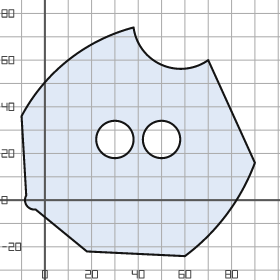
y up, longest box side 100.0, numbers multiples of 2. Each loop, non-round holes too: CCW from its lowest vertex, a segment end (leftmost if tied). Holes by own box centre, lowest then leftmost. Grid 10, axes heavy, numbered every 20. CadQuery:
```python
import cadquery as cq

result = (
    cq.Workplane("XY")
    .moveTo(60.0, -24.0)
    .threePointArc((78.0, -6.0), (90.0, 16.0))
    .lineTo(70.0, 60.0)
    .threePointArc((50.0, 58.0), (38.0, 74.0))
    .threePointArc((10.0, 60.0), (-10.0, 36.0))
    .lineTo(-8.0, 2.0)
    .threePointArc((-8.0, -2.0), (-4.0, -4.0))
    .lineTo(18.0, -22.0)
    .close()
    .moveTo(30.0, 26.0)
    .circle(8.0)
    .moveTo(50.0, 26.0)
    .circle(8.0)
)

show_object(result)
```